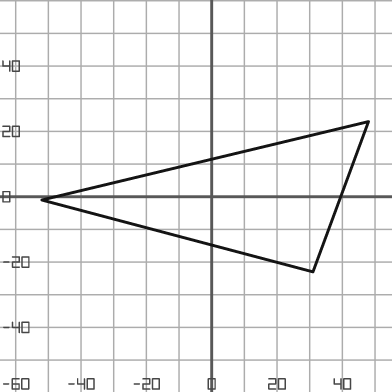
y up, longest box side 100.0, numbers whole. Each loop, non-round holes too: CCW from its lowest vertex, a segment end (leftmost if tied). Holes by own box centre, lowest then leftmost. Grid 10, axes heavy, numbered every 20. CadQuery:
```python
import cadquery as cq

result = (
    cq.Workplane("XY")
    .moveTo(31.0, -23.0)
    .lineTo(48.0, 23.0)
    .lineTo(-52.0, -1.0)
    .close()
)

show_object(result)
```